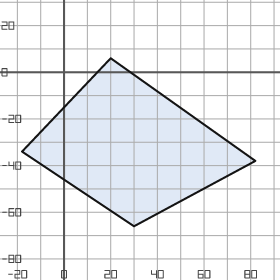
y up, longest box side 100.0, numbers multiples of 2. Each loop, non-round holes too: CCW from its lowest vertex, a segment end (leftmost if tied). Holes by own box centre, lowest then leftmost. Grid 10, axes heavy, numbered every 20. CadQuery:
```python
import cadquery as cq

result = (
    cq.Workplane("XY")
    .moveTo(30.0, -66.0)
    .lineTo(82.0, -38.0)
    .lineTo(20.0, 6.0)
    .lineTo(-18.0, -34.0)
    .close()
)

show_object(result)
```